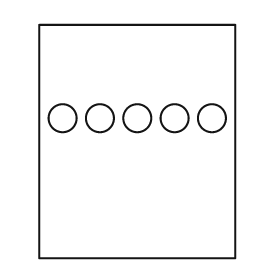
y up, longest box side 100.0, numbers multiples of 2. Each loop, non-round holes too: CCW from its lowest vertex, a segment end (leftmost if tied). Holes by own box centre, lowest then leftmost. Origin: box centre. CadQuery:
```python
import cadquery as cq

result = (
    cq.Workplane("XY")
    .moveTo(-42.0, -50.0)
    .lineTo(42.0, -50.0)
    .lineTo(42.0, 50.0)
    .lineTo(-42.0, 50.0)
    .close()
    .moveTo(-32.0, 10.0)
    .circle(6.0)
    .moveTo(-16.0, 10.0)
    .circle(6.0)
    .moveTo(0.0, 10.0)
    .circle(6.0)
    .moveTo(16.0, 10.0)
    .circle(6.0)
    .moveTo(32.0, 10.0)
    .circle(6.0)
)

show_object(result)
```